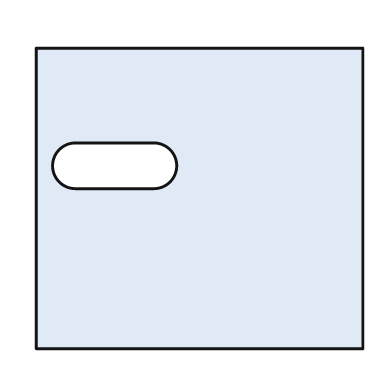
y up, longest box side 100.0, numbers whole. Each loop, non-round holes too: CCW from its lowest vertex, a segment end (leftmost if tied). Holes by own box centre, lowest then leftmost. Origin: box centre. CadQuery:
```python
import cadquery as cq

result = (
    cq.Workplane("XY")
    .moveTo(-50.0, -46.0)
    .lineTo(50.0, -46.0)
    .lineTo(50.0, 46.0)
    .lineTo(-50.0, 46.0)
    .close()
    .moveTo(-38.0, 3.0)
    .lineTo(-14.0, 3.0)
    .threePointArc((-7.0, 10.0), (-14.0, 17.0))
    .lineTo(-38.0, 17.0)
    .threePointArc((-45.0, 10.0), (-38.0, 3.0))
    .close()
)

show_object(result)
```